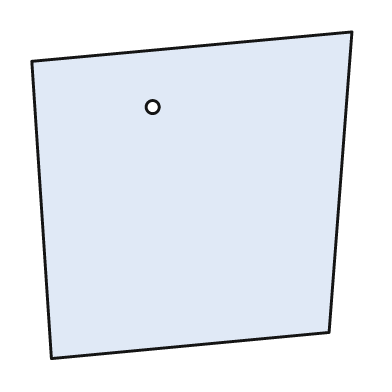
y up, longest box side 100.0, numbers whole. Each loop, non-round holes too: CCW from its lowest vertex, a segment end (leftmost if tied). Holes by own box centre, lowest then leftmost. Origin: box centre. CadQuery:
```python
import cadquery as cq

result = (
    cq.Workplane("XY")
    .moveTo(-43.0, -50.0)
    .lineTo(42.0, -42.0)
    .lineTo(49.0, 50.0)
    .lineTo(-49.0, 41.0)
    .close()
    .moveTo(-12.0, 27.0)
    .circle(2.0)
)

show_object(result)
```